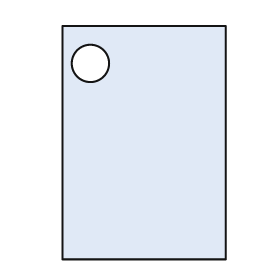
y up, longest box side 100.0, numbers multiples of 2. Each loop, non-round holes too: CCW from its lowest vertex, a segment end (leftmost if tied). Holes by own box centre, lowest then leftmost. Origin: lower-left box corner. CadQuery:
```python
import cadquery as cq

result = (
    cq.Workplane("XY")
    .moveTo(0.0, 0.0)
    .lineTo(70.0, 0.0)
    .lineTo(70.0, 100.0)
    .lineTo(0.0, 100.0)
    .close()
    .moveTo(12.0, 84.0)
    .circle(8.0)
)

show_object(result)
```